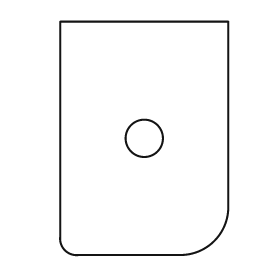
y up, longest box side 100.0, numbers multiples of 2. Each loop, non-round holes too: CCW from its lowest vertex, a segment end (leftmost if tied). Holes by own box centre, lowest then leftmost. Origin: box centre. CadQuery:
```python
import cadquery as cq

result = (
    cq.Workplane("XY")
    .moveTo(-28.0, -50.0)
    .lineTo(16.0, -50.0)
    .threePointArc((30.0, -44.0), (36.0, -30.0))
    .lineTo(36.0, 50.0)
    .lineTo(-36.0, 50.0)
    .lineTo(-36.0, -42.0)
    .threePointArc((-34.0, -48.0), (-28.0, -50.0))
    .close()
    .moveTo(0.0, 0.0)
    .circle(8.0)
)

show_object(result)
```